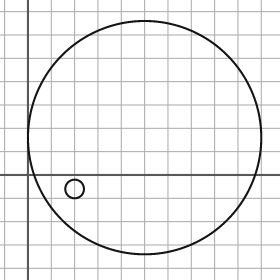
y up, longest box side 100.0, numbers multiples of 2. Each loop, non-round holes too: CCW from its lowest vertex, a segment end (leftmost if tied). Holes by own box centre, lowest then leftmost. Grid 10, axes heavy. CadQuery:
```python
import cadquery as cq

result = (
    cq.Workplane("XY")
    .moveTo(50.0, 16.0)
    .circle(50.0)
    .moveTo(20.0, -6.0)
    .circle(4.0)
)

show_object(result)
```